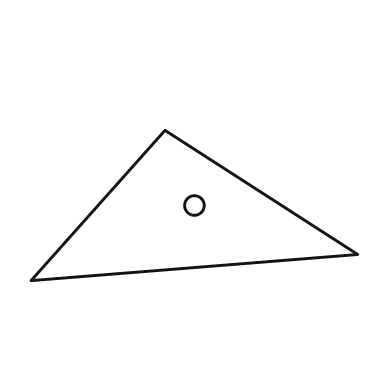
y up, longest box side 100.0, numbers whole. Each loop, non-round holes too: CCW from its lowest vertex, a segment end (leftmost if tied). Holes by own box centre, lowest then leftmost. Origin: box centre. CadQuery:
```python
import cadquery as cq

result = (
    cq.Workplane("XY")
    .moveTo(-50.0, -23.0)
    .lineTo(50.0, -15.0)
    .lineTo(-9.0, 23.0)
    .close()
    .moveTo(0.0, 0.0)
    .circle(3.0)
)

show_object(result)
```